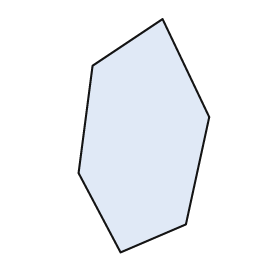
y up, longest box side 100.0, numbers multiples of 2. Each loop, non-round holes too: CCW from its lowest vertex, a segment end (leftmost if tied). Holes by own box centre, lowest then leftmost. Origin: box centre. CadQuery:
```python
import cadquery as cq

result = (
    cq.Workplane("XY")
    .moveTo(-10.0, -50.0)
    .lineTo(18.0, -38.0)
    .lineTo(28.0, 8.0)
    .lineTo(8.0, 50.0)
    .lineTo(-22.0, 30.0)
    .lineTo(-28.0, -16.0)
    .close()
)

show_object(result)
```